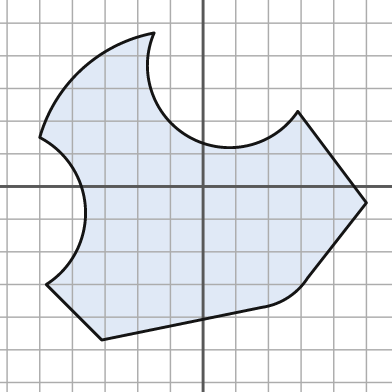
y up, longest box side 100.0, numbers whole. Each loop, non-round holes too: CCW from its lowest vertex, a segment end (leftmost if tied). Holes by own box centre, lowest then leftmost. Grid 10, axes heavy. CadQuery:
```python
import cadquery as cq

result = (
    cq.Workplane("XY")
    .moveTo(-31.0, -47.0)
    .lineTo(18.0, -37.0)
    .threePointArc((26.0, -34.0), (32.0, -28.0))
    .lineTo(50.0, -5.0)
    .lineTo(29.0, 23.0)
    .threePointArc((-4.0, 15.0), (-15.0, 47.0))
    .threePointArc((-37.0, 36.0), (-50.0, 15.0))
    .threePointArc((-36.0, -7.0), (-48.0, -30.0))
    .close()
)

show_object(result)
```